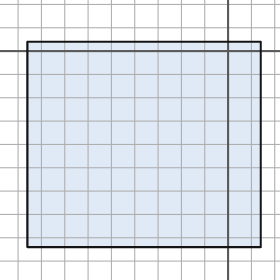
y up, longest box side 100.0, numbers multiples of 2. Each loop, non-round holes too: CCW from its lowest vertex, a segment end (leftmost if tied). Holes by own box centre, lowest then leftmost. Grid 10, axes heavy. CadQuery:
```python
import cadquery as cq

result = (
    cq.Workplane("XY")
    .moveTo(-86.0, -84.0)
    .lineTo(14.0, -84.0)
    .lineTo(14.0, 4.0)
    .lineTo(-86.0, 4.0)
    .close()
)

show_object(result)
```